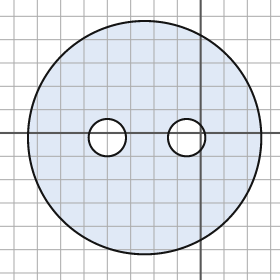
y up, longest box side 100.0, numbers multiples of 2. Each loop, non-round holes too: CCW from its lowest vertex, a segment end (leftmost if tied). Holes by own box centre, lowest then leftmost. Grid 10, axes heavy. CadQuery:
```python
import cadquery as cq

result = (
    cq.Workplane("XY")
    .moveTo(-24.0, -2.0)
    .circle(50.0)
    .moveTo(-40.0, -2.0)
    .circle(8.0)
    .moveTo(-6.0, -2.0)
    .circle(8.0)
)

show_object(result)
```